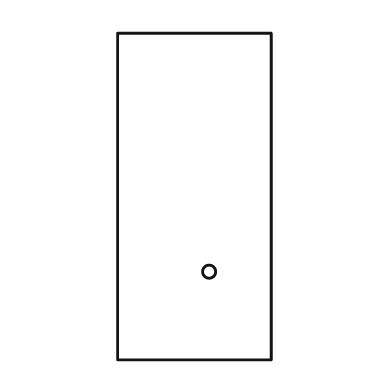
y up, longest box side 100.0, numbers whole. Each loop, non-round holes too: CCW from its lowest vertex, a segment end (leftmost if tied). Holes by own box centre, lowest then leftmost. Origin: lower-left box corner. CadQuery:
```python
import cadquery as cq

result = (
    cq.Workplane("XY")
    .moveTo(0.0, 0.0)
    .lineTo(47.0, 0.0)
    .lineTo(47.0, 100.0)
    .lineTo(0.0, 100.0)
    .close()
    .moveTo(28.0, 27.0)
    .circle(2.0)
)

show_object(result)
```